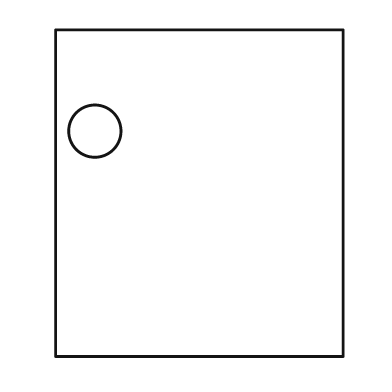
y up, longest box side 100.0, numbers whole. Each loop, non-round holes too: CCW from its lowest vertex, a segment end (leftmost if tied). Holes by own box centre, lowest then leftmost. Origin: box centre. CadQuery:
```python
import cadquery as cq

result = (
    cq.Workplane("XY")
    .moveTo(-44.0, -50.0)
    .lineTo(44.0, -50.0)
    .lineTo(44.0, 50.0)
    .lineTo(-44.0, 50.0)
    .close()
    .moveTo(-32.0, 19.0)
    .circle(8.0)
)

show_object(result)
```